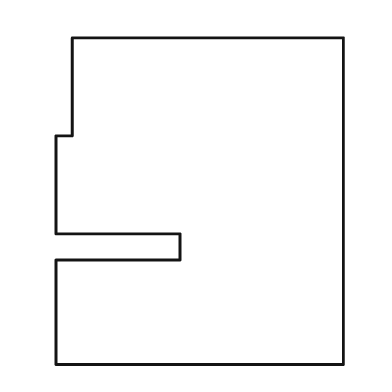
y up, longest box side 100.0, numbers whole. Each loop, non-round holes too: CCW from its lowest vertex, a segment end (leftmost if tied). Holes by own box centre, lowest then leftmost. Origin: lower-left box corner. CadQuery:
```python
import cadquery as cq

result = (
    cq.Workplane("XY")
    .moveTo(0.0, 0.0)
    .lineTo(88.0, 0.0)
    .lineTo(88.0, 100.0)
    .lineTo(5.0, 100.0)
    .lineTo(5.0, 70.0)
    .lineTo(0.0, 70.0)
    .lineTo(0.0, 40.0)
    .lineTo(38.0, 40.0)
    .lineTo(38.0, 32.0)
    .lineTo(0.0, 32.0)
    .close()
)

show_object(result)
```